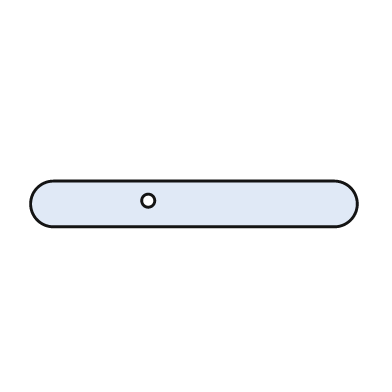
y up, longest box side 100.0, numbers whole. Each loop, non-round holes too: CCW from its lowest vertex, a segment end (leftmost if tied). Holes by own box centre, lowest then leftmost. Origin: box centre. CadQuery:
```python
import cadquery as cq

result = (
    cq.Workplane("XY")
    .moveTo(-43.0, -7.0)
    .lineTo(43.0, -7.0)
    .threePointArc((50.0, 0.0), (43.0, 7.0))
    .lineTo(-43.0, 7.0)
    .threePointArc((-50.0, 0.0), (-43.0, -7.0))
    .close()
    .moveTo(-14.0, 1.0)
    .circle(2.0)
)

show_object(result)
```